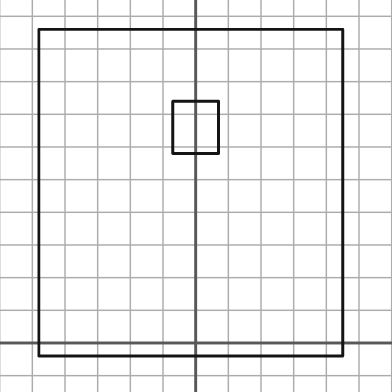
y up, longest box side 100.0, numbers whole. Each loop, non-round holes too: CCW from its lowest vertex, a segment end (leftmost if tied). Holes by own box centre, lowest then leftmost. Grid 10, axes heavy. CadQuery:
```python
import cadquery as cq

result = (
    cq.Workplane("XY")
    .moveTo(-48.0, -4.0)
    .lineTo(45.0, -4.0)
    .lineTo(45.0, 96.0)
    .lineTo(-48.0, 96.0)
    .close()
    .moveTo(-7.0, 58.0)
    .lineTo(7.0, 58.0)
    .lineTo(7.0, 74.0)
    .lineTo(-7.0, 74.0)
    .close()
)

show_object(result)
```